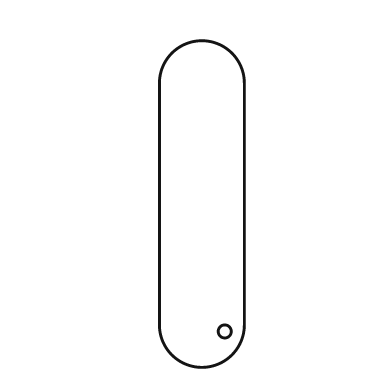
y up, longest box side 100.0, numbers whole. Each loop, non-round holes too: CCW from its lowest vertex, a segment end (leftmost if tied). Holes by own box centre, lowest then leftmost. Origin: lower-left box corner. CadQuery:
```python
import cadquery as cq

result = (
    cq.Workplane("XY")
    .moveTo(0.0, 13.0)
    .threePointArc((13.0, 0.0), (26.0, 13.0))
    .lineTo(26.0, 87.0)
    .threePointArc((13.0, 100.0), (0.0, 87.0))
    .close()
    .moveTo(20.0, 11.0)
    .circle(2.0)
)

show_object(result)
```